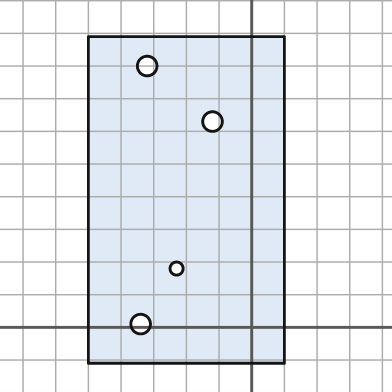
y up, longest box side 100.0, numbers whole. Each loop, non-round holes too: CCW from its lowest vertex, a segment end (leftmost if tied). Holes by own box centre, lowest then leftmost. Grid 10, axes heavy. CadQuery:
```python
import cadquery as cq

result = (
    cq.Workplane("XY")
    .moveTo(-50.0, -11.0)
    .lineTo(10.0, -11.0)
    .lineTo(10.0, 89.0)
    .lineTo(-50.0, 89.0)
    .close()
    .moveTo(-34.0, 1.0)
    .circle(3.0)
    .moveTo(-23.0, 18.0)
    .circle(2.0)
    .moveTo(-12.0, 63.0)
    .circle(3.0)
    .moveTo(-32.0, 80.0)
    .circle(3.0)
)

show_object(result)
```